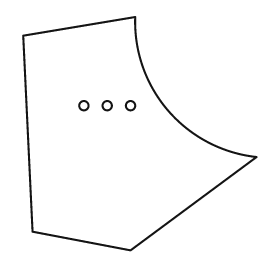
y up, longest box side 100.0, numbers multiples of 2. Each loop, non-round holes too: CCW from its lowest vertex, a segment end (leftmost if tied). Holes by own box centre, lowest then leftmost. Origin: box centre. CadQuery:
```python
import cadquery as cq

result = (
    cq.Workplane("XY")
    .moveTo(-4.0, -50.0)
    .lineTo(50.0, -10.0)
    .threePointArc((12.0, 10.0), (-2.0, 50.0))
    .lineTo(-50.0, 42.0)
    .lineTo(-46.0, -42.0)
    .close()
    .moveTo(-24.0, 12.0)
    .circle(2.0)
    .moveTo(-14.0, 12.0)
    .circle(2.0)
    .moveTo(-4.0, 12.0)
    .circle(2.0)
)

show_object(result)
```